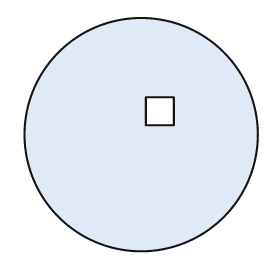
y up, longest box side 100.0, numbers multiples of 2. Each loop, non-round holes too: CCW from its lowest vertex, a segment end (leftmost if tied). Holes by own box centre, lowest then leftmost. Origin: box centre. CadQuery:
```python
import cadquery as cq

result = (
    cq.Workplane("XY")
    .moveTo(0.0, 0.0)
    .circle(50.0)
    .moveTo(2.0, 4.0)
    .lineTo(14.0, 4.0)
    .lineTo(14.0, 16.0)
    .lineTo(2.0, 16.0)
    .close()
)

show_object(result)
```